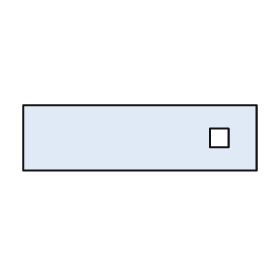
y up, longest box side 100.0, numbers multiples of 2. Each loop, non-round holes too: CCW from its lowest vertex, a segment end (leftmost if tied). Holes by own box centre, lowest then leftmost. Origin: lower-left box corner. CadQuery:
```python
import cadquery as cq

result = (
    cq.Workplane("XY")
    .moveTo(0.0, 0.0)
    .lineTo(100.0, 0.0)
    .lineTo(100.0, 28.0)
    .lineTo(0.0, 28.0)
    .close()
    .moveTo(80.0, 10.0)
    .lineTo(88.0, 10.0)
    .lineTo(88.0, 18.0)
    .lineTo(80.0, 18.0)
    .close()
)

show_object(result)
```